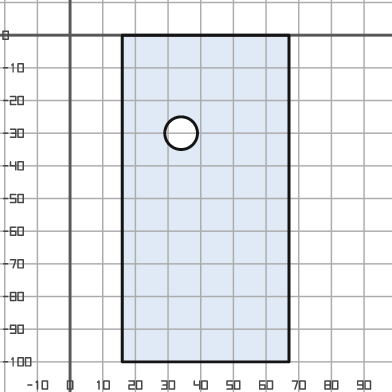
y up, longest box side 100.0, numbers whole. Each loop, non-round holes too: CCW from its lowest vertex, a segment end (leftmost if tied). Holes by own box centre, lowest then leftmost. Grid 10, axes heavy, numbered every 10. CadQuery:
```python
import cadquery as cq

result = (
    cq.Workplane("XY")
    .moveTo(16.0, -100.0)
    .lineTo(67.0, -100.0)
    .lineTo(67.0, 0.0)
    .lineTo(16.0, 0.0)
    .close()
    .moveTo(34.0, -30.0)
    .circle(5.0)
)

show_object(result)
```